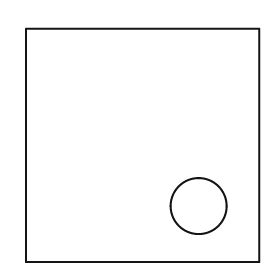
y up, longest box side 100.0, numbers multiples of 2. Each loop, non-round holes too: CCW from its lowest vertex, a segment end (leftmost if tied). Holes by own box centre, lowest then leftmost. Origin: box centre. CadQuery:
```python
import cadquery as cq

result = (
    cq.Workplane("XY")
    .moveTo(-50.0, -50.0)
    .lineTo(50.0, -50.0)
    .lineTo(50.0, 50.0)
    .lineTo(-50.0, 50.0)
    .close()
    .moveTo(24.0, -26.0)
    .circle(12.0)
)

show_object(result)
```